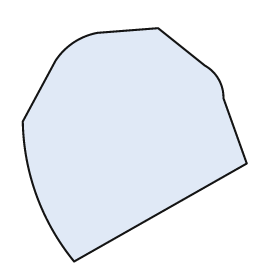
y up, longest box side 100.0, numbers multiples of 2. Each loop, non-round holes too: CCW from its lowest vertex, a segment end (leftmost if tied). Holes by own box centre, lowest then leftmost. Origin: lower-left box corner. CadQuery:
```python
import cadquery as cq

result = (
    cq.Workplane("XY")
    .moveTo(22.0, 0.0)
    .lineTo(96.0, 42.0)
    .lineTo(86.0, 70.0)
    .threePointArc((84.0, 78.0), (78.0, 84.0))
    .lineTo(58.0, 100.0)
    .lineTo(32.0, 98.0)
    .threePointArc((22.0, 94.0), (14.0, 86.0))
    .lineTo(0.0, 60.0)
    .threePointArc((6.0, 28.0), (22.0, 0.0))
    .close()
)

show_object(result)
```